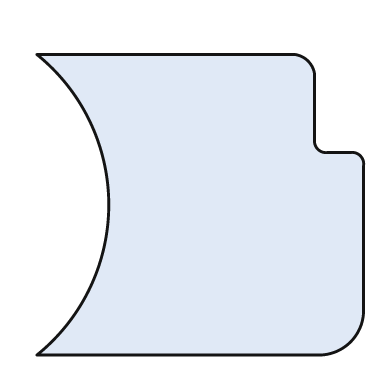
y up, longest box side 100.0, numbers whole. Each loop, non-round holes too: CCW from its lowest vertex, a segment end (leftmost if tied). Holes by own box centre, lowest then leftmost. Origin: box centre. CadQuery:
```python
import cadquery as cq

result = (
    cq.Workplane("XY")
    .moveTo(-50.0, -46.0)
    .lineTo(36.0, -46.0)
    .threePointArc((46.0, -42.0), (50.0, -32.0))
    .lineTo(50.0, 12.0)
    .threePointArc((49.0, 15.0), (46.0, 16.0))
    .lineTo(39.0, 16.0)
    .threePointArc((36.0, 17.0), (35.0, 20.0))
    .lineTo(35.0, 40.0)
    .threePointArc((33.0, 44.0), (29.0, 46.0))
    .lineTo(-50.0, 46.0)
    .threePointArc((-28.0, 0.0), (-50.0, -46.0))
    .close()
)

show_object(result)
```